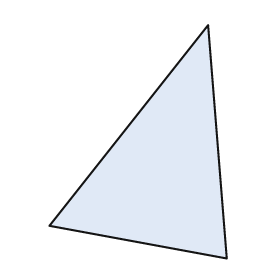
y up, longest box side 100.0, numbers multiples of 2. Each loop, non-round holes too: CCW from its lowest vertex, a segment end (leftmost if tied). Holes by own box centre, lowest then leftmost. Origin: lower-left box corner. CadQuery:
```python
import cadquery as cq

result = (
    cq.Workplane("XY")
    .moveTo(76.0, 0.0)
    .lineTo(68.0, 100.0)
    .lineTo(0.0, 14.0)
    .close()
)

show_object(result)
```